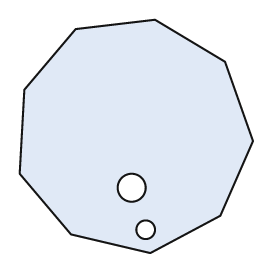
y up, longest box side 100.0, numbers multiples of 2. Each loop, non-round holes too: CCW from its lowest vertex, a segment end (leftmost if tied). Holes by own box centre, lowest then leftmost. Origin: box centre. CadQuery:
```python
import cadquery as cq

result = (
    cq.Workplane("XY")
    .moveTo(6.0, -50.0)
    .lineTo(36.0, -34.0)
    .lineTo(50.0, -2.0)
    .lineTo(38.0, 32.0)
    .lineTo(8.0, 50.0)
    .lineTo(-26.0, 46.0)
    .lineTo(-48.0, 20.0)
    .lineTo(-50.0, -16.0)
    .lineTo(-28.0, -42.0)
    .close()
    .moveTo(4.0, -40.0)
    .circle(4.0)
    .moveTo(-2.0, -22.0)
    .circle(6.0)
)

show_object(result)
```